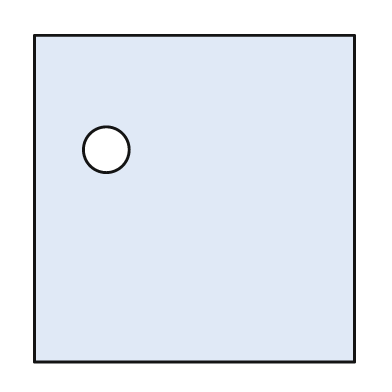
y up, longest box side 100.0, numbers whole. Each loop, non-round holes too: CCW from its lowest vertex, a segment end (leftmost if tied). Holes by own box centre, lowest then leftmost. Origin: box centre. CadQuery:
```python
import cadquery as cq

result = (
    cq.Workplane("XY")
    .moveTo(-49.0, -50.0)
    .lineTo(49.0, -50.0)
    .lineTo(49.0, 50.0)
    .lineTo(-49.0, 50.0)
    .close()
    .moveTo(-27.0, 15.0)
    .circle(7.0)
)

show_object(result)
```